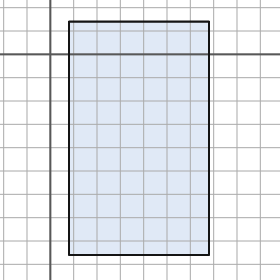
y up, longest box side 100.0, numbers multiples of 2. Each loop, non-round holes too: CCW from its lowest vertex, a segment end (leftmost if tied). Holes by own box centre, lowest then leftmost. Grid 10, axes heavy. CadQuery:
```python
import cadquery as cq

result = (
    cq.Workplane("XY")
    .moveTo(8.0, -86.0)
    .lineTo(68.0, -86.0)
    .lineTo(68.0, 14.0)
    .lineTo(8.0, 14.0)
    .close()
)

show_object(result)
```